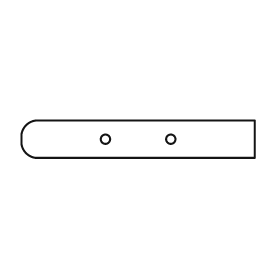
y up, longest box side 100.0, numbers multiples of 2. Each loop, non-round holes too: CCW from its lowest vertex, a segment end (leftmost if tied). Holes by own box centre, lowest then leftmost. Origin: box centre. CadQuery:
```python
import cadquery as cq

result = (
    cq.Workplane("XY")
    .moveTo(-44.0, -8.0)
    .lineTo(50.0, -8.0)
    .lineTo(50.0, 8.0)
    .lineTo(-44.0, 8.0)
    .threePointArc((-48.0, 6.0), (-50.0, 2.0))
    .lineTo(-50.0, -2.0)
    .threePointArc((-48.0, -6.0), (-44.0, -8.0))
    .close()
    .moveTo(-14.0, 0.0)
    .circle(2.0)
    .moveTo(14.0, 0.0)
    .circle(2.0)
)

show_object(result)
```